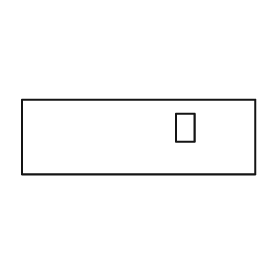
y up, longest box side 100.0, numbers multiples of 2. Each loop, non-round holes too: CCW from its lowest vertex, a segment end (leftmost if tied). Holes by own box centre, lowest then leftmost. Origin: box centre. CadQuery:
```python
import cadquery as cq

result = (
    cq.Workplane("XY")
    .moveTo(-50.0, -16.0)
    .lineTo(50.0, -16.0)
    .lineTo(50.0, 16.0)
    .lineTo(-50.0, 16.0)
    .close()
    .moveTo(16.0, -2.0)
    .lineTo(24.0, -2.0)
    .lineTo(24.0, 10.0)
    .lineTo(16.0, 10.0)
    .close()
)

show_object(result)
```